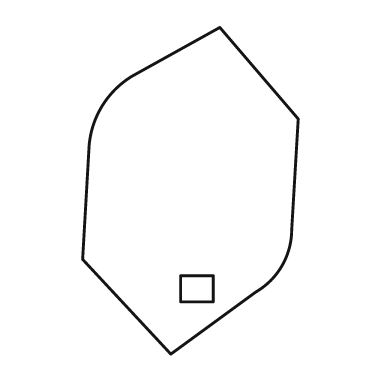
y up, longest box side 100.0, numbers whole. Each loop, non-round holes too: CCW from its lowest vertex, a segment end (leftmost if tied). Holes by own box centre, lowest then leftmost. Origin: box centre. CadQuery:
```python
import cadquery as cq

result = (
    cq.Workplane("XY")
    .moveTo(-6.0, -50.0)
    .lineTo(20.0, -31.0)
    .threePointArc((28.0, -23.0), (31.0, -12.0))
    .lineTo(33.0, 22.0)
    .lineTo(9.0, 50.0)
    .lineTo(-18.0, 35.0)
    .threePointArc((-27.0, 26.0), (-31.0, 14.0))
    .lineTo(-33.0, -21.0)
    .close()
    .moveTo(-3.0, -34.0)
    .lineTo(7.0, -34.0)
    .lineTo(7.0, -26.0)
    .lineTo(-3.0, -26.0)
    .close()
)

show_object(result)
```